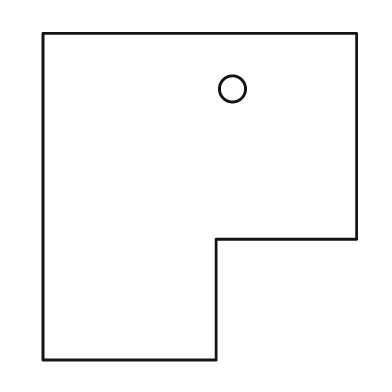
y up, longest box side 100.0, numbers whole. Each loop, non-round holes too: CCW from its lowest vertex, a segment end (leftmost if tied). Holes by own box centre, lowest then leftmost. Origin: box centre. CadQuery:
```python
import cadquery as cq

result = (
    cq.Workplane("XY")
    .moveTo(-48.0, -50.0)
    .lineTo(5.0, -50.0)
    .lineTo(5.0, -13.0)
    .lineTo(48.0, -13.0)
    .lineTo(48.0, 50.0)
    .lineTo(-48.0, 50.0)
    .close()
    .moveTo(10.0, 33.0)
    .circle(4.0)
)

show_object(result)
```